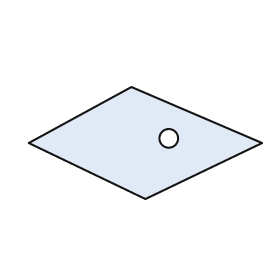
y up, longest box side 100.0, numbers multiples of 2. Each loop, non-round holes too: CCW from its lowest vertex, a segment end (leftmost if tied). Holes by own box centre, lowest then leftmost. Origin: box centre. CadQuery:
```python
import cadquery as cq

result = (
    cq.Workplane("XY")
    .moveTo(0.0, -24.0)
    .lineTo(50.0, 0.0)
    .lineTo(-6.0, 24.0)
    .lineTo(-50.0, 0.0)
    .close()
    .moveTo(10.0, 2.0)
    .circle(4.0)
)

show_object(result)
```